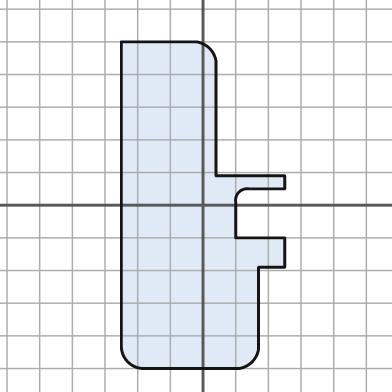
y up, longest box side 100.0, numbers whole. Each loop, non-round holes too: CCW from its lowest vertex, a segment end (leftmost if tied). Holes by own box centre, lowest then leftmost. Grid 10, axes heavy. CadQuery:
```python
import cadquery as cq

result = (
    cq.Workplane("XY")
    .moveTo(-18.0, -50.0)
    .lineTo(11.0, -50.0)
    .threePointArc((15.0, -48.0), (17.0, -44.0))
    .lineTo(17.0, -19.0)
    .lineTo(25.0, -19.0)
    .lineTo(25.0, -10.0)
    .lineTo(10.0, -10.0)
    .lineTo(10.0, 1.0)
    .threePointArc((11.0, 4.0), (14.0, 5.0))
    .lineTo(25.0, 5.0)
    .lineTo(25.0, 9.0)
    .lineTo(4.0, 9.0)
    .lineTo(4.0, 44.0)
    .threePointArc((2.0, 48.0), (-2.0, 50.0))
    .lineTo(-25.0, 50.0)
    .lineTo(-25.0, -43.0)
    .threePointArc((-23.0, -48.0), (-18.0, -50.0))
    .close()
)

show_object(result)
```